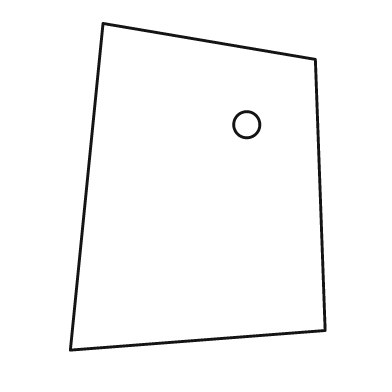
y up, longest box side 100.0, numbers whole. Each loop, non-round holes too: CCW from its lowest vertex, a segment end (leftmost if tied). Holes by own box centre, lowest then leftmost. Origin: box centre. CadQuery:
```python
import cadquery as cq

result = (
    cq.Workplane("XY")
    .moveTo(-39.0, -50.0)
    .lineTo(39.0, -44.0)
    .lineTo(36.0, 39.0)
    .lineTo(-29.0, 50.0)
    .close()
    .moveTo(15.0, 19.0)
    .circle(4.0)
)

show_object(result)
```